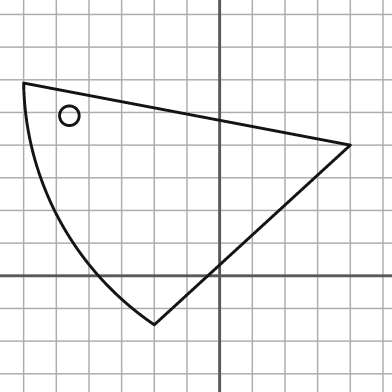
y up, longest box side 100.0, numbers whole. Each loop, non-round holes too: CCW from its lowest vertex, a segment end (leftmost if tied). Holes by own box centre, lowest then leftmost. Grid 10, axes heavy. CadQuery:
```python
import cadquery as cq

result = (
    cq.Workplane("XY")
    .moveTo(-20.0, -15.0)
    .lineTo(40.0, 40.0)
    .lineTo(-60.0, 59.0)
    .threePointArc((-49.0, 17.0), (-20.0, -15.0))
    .close()
    .moveTo(-46.0, 49.0)
    .circle(3.0)
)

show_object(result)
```